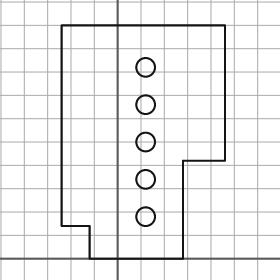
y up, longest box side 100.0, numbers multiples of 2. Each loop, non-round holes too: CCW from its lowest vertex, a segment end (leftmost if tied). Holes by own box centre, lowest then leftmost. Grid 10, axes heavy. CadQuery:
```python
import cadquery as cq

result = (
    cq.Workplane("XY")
    .moveTo(-12.0, 0.0)
    .lineTo(28.0, 0.0)
    .lineTo(28.0, 42.0)
    .lineTo(46.0, 42.0)
    .lineTo(46.0, 100.0)
    .lineTo(-24.0, 100.0)
    .lineTo(-24.0, 14.0)
    .lineTo(-12.0, 14.0)
    .close()
    .moveTo(12.0, 18.0)
    .circle(4.0)
    .moveTo(12.0, 34.0)
    .circle(4.0)
    .moveTo(12.0, 50.0)
    .circle(4.0)
    .moveTo(12.0, 66.0)
    .circle(4.0)
    .moveTo(12.0, 82.0)
    .circle(4.0)
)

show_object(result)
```